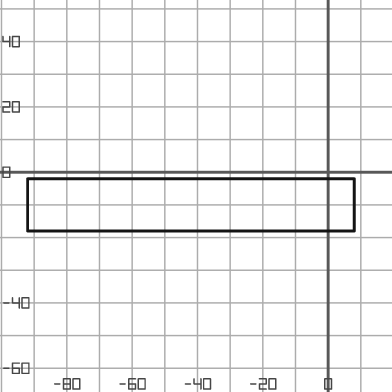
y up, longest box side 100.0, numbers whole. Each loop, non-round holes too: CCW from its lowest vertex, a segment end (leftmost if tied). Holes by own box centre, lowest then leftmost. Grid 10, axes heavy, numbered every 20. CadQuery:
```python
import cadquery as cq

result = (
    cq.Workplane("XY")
    .moveTo(-92.0, -18.0)
    .lineTo(8.0, -18.0)
    .lineTo(8.0, -2.0)
    .lineTo(-92.0, -2.0)
    .close()
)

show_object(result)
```